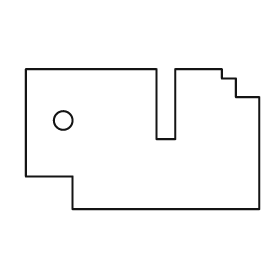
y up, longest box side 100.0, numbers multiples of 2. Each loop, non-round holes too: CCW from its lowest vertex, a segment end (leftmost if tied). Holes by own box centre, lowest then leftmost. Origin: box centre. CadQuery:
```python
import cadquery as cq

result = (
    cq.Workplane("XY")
    .moveTo(-30.0, -30.0)
    .lineTo(50.0, -30.0)
    .lineTo(50.0, 18.0)
    .lineTo(40.0, 18.0)
    .lineTo(40.0, 26.0)
    .lineTo(34.0, 26.0)
    .lineTo(34.0, 30.0)
    .lineTo(14.0, 30.0)
    .lineTo(14.0, 0.0)
    .lineTo(6.0, 0.0)
    .lineTo(6.0, 30.0)
    .lineTo(-50.0, 30.0)
    .lineTo(-50.0, -16.0)
    .lineTo(-30.0, -16.0)
    .close()
    .moveTo(-34.0, 8.0)
    .circle(4.0)
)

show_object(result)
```